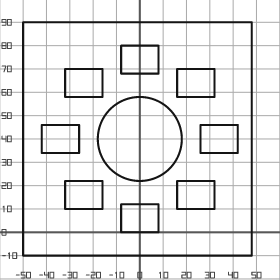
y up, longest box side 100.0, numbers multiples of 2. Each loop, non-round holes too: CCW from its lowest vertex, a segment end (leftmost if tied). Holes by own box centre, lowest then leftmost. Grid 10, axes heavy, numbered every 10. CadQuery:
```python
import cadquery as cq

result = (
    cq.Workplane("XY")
    .moveTo(-50.0, -10.0)
    .lineTo(48.0, -10.0)
    .lineTo(48.0, 90.0)
    .lineTo(-50.0, 90.0)
    .close()
    .moveTo(-8.0, 0.0)
    .lineTo(8.0, 0.0)
    .lineTo(8.0, 12.0)
    .lineTo(-8.0, 12.0)
    .close()
    .moveTo(-32.0, 10.0)
    .lineTo(-16.0, 10.0)
    .lineTo(-16.0, 22.0)
    .lineTo(-32.0, 22.0)
    .close()
    .moveTo(16.0, 10.0)
    .lineTo(32.0, 10.0)
    .lineTo(32.0, 22.0)
    .lineTo(16.0, 22.0)
    .close()
    .moveTo(-42.0, 34.0)
    .lineTo(-26.0, 34.0)
    .lineTo(-26.0, 46.0)
    .lineTo(-42.0, 46.0)
    .close()
    .moveTo(0.0, 40.0)
    .circle(18.0)
    .moveTo(26.0, 34.0)
    .lineTo(42.0, 34.0)
    .lineTo(42.0, 46.0)
    .lineTo(26.0, 46.0)
    .close()
    .moveTo(-32.0, 58.0)
    .lineTo(-16.0, 58.0)
    .lineTo(-16.0, 70.0)
    .lineTo(-32.0, 70.0)
    .close()
    .moveTo(16.0, 58.0)
    .lineTo(32.0, 58.0)
    .lineTo(32.0, 70.0)
    .lineTo(16.0, 70.0)
    .close()
    .moveTo(-8.0, 68.0)
    .lineTo(8.0, 68.0)
    .lineTo(8.0, 80.0)
    .lineTo(-8.0, 80.0)
    .close()
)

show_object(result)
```